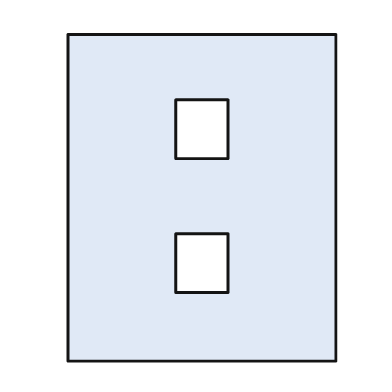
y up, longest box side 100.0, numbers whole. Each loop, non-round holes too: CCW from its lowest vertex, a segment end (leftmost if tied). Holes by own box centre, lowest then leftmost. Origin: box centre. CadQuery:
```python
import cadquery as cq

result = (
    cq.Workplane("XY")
    .moveTo(-41.0, -50.0)
    .lineTo(41.0, -50.0)
    .lineTo(41.0, 50.0)
    .lineTo(-41.0, 50.0)
    .close()
    .moveTo(-8.0, -29.0)
    .lineTo(8.0, -29.0)
    .lineTo(8.0, -11.0)
    .lineTo(-8.0, -11.0)
    .close()
    .moveTo(-8.0, 12.0)
    .lineTo(8.0, 12.0)
    .lineTo(8.0, 30.0)
    .lineTo(-8.0, 30.0)
    .close()
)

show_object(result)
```